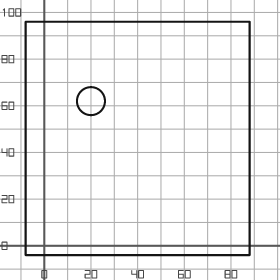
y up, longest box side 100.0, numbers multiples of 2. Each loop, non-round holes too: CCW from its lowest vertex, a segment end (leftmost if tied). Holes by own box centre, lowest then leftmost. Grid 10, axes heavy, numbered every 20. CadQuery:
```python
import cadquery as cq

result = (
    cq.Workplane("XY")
    .moveTo(-8.0, -4.0)
    .lineTo(88.0, -4.0)
    .lineTo(88.0, 96.0)
    .lineTo(-8.0, 96.0)
    .close()
    .moveTo(20.0, 62.0)
    .circle(6.0)
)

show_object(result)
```